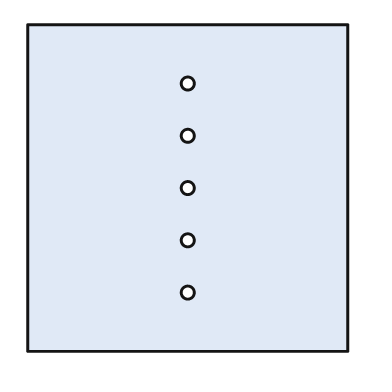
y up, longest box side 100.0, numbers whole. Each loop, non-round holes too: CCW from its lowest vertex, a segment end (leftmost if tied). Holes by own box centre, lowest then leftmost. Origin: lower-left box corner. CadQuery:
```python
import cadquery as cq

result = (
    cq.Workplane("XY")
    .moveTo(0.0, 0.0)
    .lineTo(98.0, 0.0)
    .lineTo(98.0, 100.0)
    .lineTo(0.0, 100.0)
    .close()
    .moveTo(49.0, 18.0)
    .circle(2.0)
    .moveTo(49.0, 34.0)
    .circle(2.0)
    .moveTo(49.0, 50.0)
    .circle(2.0)
    .moveTo(49.0, 66.0)
    .circle(2.0)
    .moveTo(49.0, 82.0)
    .circle(2.0)
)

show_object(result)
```